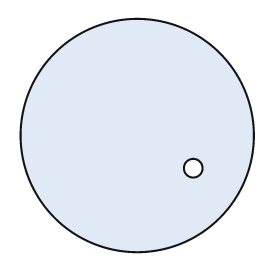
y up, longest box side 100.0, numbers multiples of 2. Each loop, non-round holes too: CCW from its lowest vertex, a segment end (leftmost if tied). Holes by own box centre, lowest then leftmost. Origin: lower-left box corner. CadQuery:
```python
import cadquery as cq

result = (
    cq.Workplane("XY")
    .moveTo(50.0, 50.0)
    .circle(50.0)
    .moveTo(74.0, 36.0)
    .circle(4.0)
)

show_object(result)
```